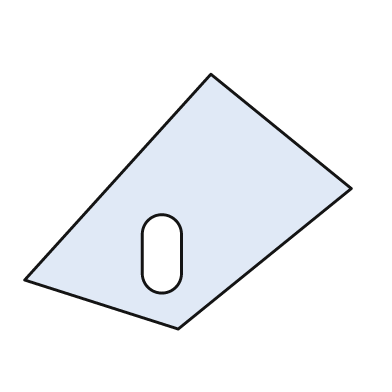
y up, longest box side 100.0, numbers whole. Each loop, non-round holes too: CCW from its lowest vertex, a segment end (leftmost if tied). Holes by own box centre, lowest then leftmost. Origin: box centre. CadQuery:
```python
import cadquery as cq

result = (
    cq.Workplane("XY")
    .moveTo(-3.0, -39.0)
    .lineTo(50.0, 4.0)
    .lineTo(7.0, 39.0)
    .lineTo(-50.0, -24.0)
    .close()
    .moveTo(-14.0, -22.0)
    .threePointArc((-8.0, -28.0), (-2.0, -22.0))
    .lineTo(-2.0, -10.0)
    .threePointArc((-8.0, -4.0), (-14.0, -10.0))
    .close()
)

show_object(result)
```